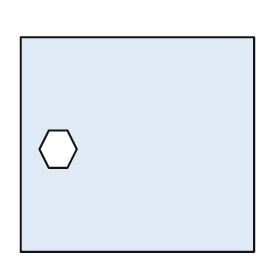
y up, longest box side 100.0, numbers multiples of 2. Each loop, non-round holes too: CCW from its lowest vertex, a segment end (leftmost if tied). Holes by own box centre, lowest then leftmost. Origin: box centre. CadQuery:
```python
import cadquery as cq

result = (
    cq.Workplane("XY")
    .moveTo(-50.0, -46.0)
    .lineTo(50.0, -46.0)
    .lineTo(50.0, 46.0)
    .lineTo(-50.0, 46.0)
    .close()
    .moveTo(-38.0, -10.0)
    .lineTo(-30.0, -10.0)
    .lineTo(-26.0, -2.0)
    .lineTo(-30.0, 6.0)
    .lineTo(-38.0, 6.0)
    .lineTo(-42.0, -2.0)
    .close()
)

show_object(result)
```